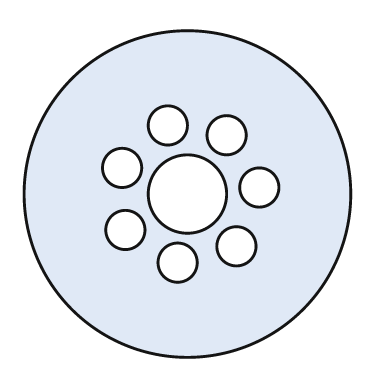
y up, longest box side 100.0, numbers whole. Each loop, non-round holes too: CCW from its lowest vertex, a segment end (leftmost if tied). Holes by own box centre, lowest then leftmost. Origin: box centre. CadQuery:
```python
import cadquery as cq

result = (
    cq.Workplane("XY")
    .moveTo(0.0, 0.0)
    .circle(50.0)
    .moveTo(-3.0, -21.0)
    .circle(6.0)
    .moveTo(15.0, -16.0)
    .circle(6.0)
    .moveTo(-19.0, -11.0)
    .circle(6.0)
    .moveTo(0.0, 0.0)
    .circle(12.0)
    .moveTo(22.0, 2.0)
    .circle(6.0)
    .moveTo(-20.0, 8.0)
    .circle(6.0)
    .moveTo(12.0, 18.0)
    .circle(6.0)
    .moveTo(-6.0, 21.0)
    .circle(6.0)
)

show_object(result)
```